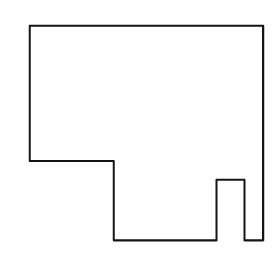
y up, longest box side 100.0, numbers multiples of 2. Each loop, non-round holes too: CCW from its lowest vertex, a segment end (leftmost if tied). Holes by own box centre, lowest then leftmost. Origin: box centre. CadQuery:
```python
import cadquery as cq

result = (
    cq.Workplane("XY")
    .moveTo(-14.0, -46.0)
    .lineTo(30.0, -46.0)
    .lineTo(30.0, -20.0)
    .lineTo(42.0, -20.0)
    .lineTo(42.0, -46.0)
    .lineTo(50.0, -46.0)
    .lineTo(50.0, 46.0)
    .lineTo(-50.0, 46.0)
    .lineTo(-50.0, -12.0)
    .lineTo(-14.0, -12.0)
    .close()
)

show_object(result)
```